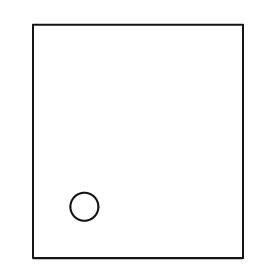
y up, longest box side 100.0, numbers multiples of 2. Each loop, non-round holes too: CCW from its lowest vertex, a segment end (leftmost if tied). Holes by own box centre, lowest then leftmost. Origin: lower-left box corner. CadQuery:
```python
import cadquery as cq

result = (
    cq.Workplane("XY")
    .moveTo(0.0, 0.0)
    .lineTo(90.0, 0.0)
    .lineTo(90.0, 100.0)
    .lineTo(0.0, 100.0)
    .close()
    .moveTo(22.0, 22.0)
    .circle(6.0)
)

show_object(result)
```